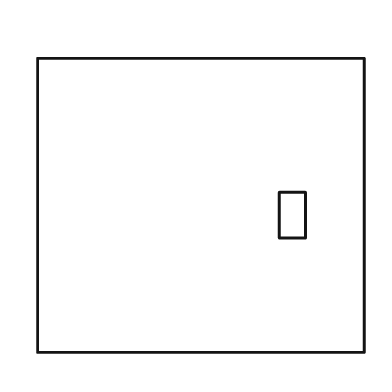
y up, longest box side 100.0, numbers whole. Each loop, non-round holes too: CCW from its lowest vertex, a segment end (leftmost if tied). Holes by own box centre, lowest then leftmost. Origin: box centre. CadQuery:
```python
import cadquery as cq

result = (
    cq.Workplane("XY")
    .moveTo(-50.0, -45.0)
    .lineTo(50.0, -45.0)
    .lineTo(50.0, 45.0)
    .lineTo(-50.0, 45.0)
    .close()
    .moveTo(24.0, -10.0)
    .lineTo(32.0, -10.0)
    .lineTo(32.0, 4.0)
    .lineTo(24.0, 4.0)
    .close()
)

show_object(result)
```